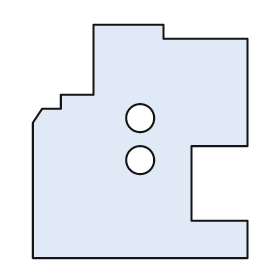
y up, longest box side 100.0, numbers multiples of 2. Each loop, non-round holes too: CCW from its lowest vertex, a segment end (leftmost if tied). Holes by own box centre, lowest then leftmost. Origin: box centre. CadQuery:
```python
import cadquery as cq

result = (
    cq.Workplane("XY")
    .moveTo(-46.0, -50.0)
    .lineTo(46.0, -50.0)
    .lineTo(46.0, -34.0)
    .lineTo(22.0, -34.0)
    .lineTo(22.0, -2.0)
    .lineTo(46.0, -2.0)
    .lineTo(46.0, 44.0)
    .lineTo(10.0, 44.0)
    .lineTo(10.0, 50.0)
    .lineTo(-20.0, 50.0)
    .lineTo(-20.0, 20.0)
    .lineTo(-34.0, 20.0)
    .lineTo(-34.0, 14.0)
    .lineTo(-42.0, 14.0)
    .lineTo(-46.0, 8.0)
    .close()
    .moveTo(0.0, -8.0)
    .circle(6.0)
    .moveTo(0.0, 10.0)
    .circle(6.0)
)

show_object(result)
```